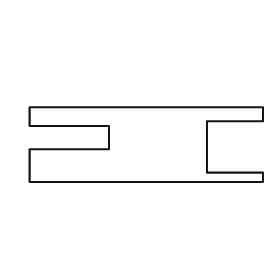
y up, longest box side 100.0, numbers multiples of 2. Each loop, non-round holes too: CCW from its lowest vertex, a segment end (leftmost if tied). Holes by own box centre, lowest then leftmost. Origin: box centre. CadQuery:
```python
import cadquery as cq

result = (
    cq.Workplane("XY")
    .moveTo(-50.0, -16.0)
    .lineTo(50.0, -16.0)
    .lineTo(50.0, -12.0)
    .lineTo(26.0, -12.0)
    .lineTo(26.0, 10.0)
    .lineTo(50.0, 10.0)
    .lineTo(50.0, 16.0)
    .lineTo(-50.0, 16.0)
    .lineTo(-50.0, 8.0)
    .lineTo(-16.0, 8.0)
    .lineTo(-16.0, -2.0)
    .lineTo(-50.0, -2.0)
    .close()
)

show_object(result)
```